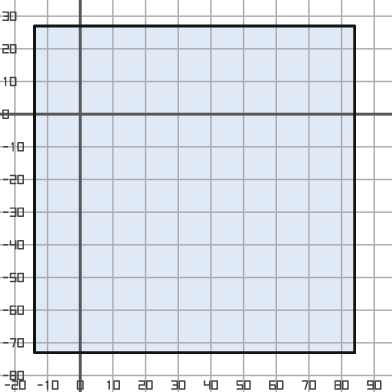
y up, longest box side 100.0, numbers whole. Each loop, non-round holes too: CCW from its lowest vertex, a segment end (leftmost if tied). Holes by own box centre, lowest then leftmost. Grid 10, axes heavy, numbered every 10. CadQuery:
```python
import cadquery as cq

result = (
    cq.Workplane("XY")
    .moveTo(-14.0, -73.0)
    .lineTo(84.0, -73.0)
    .lineTo(84.0, 27.0)
    .lineTo(-14.0, 27.0)
    .close()
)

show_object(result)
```